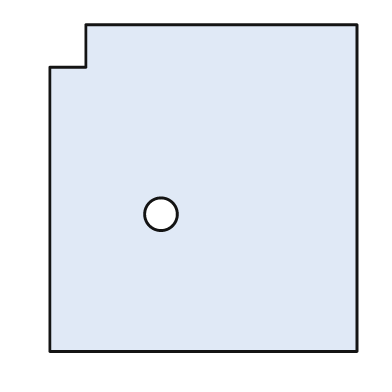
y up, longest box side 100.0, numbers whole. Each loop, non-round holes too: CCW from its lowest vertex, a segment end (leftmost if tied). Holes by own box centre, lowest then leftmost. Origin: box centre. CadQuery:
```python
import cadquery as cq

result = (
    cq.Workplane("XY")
    .moveTo(-47.0, -50.0)
    .lineTo(47.0, -50.0)
    .lineTo(47.0, 50.0)
    .lineTo(-36.0, 50.0)
    .lineTo(-36.0, 37.0)
    .lineTo(-47.0, 37.0)
    .close()
    .moveTo(-13.0, -8.0)
    .circle(5.0)
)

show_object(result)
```